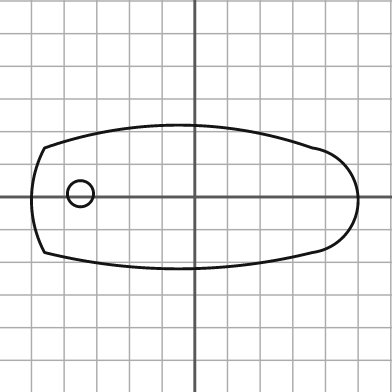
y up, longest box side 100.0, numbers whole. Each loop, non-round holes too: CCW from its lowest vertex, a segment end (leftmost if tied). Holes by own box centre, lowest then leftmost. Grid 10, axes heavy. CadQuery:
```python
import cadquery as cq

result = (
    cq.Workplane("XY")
    .moveTo(-46.0, -17.0)
    .threePointArc((-5.0, -22.0), (36.0, -17.0))
    .threePointArc((50.0, -1.0), (36.0, 15.0))
    .threePointArc((-5.0, 22.0), (-46.0, 15.0))
    .threePointArc((-50.0, -1.0), (-46.0, -17.0))
    .close()
    .moveTo(-35.0, 1.0)
    .circle(4.0)
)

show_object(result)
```